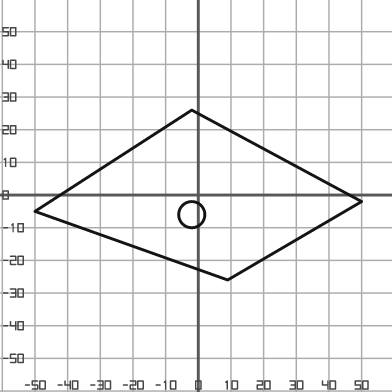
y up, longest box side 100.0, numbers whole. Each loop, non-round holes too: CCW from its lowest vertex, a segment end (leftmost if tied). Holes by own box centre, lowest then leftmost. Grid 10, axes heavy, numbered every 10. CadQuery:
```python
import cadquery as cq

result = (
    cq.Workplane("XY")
    .moveTo(9.0, -26.0)
    .lineTo(50.0, -2.0)
    .lineTo(-2.0, 26.0)
    .lineTo(-50.0, -5.0)
    .close()
    .moveTo(-2.0, -6.0)
    .circle(4.0)
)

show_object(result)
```